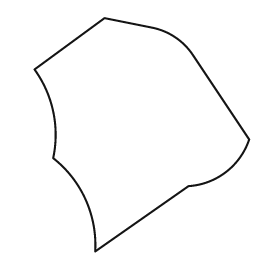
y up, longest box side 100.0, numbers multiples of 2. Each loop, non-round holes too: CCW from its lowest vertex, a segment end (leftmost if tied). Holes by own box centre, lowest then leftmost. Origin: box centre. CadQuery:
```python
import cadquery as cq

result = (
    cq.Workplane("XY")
    .moveTo(-20.0, -50.0)
    .lineTo(20.0, -22.0)
    .threePointArc((36.0, -16.0), (46.0, -2.0))
    .lineTo(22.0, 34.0)
    .threePointArc((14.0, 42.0), (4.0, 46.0))
    .lineTo(-16.0, 50.0)
    .lineTo(-46.0, 28.0)
    .threePointArc((-38.0, 10.0), (-38.0, -10.0))
    .threePointArc((-24.0, -28.0), (-20.0, -50.0))
    .close()
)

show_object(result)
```